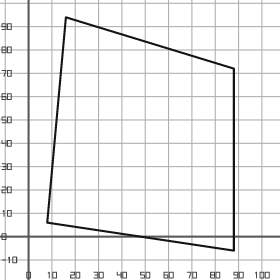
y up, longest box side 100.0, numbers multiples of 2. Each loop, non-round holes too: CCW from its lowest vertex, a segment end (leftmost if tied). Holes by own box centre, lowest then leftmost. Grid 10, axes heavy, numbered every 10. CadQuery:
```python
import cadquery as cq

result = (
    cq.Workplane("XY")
    .moveTo(88.0, -6.0)
    .lineTo(88.0, 72.0)
    .lineTo(16.0, 94.0)
    .lineTo(8.0, 6.0)
    .close()
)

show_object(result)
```